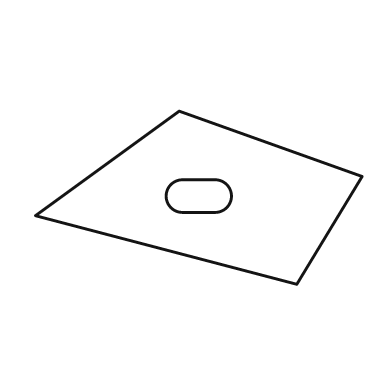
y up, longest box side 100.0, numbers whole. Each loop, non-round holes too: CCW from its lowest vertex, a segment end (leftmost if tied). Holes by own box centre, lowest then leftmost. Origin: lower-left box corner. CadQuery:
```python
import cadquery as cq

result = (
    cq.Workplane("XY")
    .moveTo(80.0, 0.0)
    .lineTo(100.0, 33.0)
    .lineTo(44.0, 53.0)
    .lineTo(0.0, 21.0)
    .close()
    .moveTo(45.0, 22.0)
    .lineTo(55.0, 22.0)
    .threePointArc((60.0, 27.0), (55.0, 32.0))
    .lineTo(45.0, 32.0)
    .threePointArc((40.0, 27.0), (45.0, 22.0))
    .close()
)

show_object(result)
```